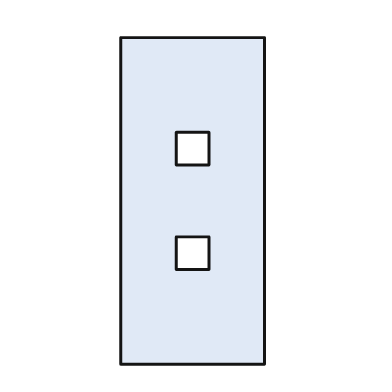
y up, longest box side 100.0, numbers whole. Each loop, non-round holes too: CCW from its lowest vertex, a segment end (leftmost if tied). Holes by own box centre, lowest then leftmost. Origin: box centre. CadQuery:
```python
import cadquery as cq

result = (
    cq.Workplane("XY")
    .moveTo(-22.0, -50.0)
    .lineTo(22.0, -50.0)
    .lineTo(22.0, 50.0)
    .lineTo(-22.0, 50.0)
    .close()
    .moveTo(-5.0, -21.0)
    .lineTo(5.0, -21.0)
    .lineTo(5.0, -11.0)
    .lineTo(-5.0, -11.0)
    .close()
    .moveTo(-5.0, 11.0)
    .lineTo(5.0, 11.0)
    .lineTo(5.0, 21.0)
    .lineTo(-5.0, 21.0)
    .close()
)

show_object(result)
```